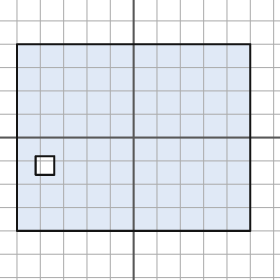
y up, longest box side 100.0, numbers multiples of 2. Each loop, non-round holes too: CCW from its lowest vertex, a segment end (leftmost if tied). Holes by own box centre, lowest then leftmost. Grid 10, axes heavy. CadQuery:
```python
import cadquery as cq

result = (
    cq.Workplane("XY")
    .moveTo(-50.0, -40.0)
    .lineTo(50.0, -40.0)
    .lineTo(50.0, 40.0)
    .lineTo(-50.0, 40.0)
    .close()
    .moveTo(-42.0, -16.0)
    .lineTo(-34.0, -16.0)
    .lineTo(-34.0, -8.0)
    .lineTo(-42.0, -8.0)
    .close()
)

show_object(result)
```